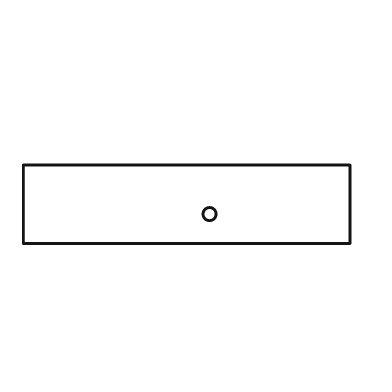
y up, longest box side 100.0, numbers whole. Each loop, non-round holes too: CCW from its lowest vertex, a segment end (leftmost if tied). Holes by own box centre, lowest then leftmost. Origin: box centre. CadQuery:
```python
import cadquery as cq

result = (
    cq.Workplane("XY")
    .moveTo(-50.0, -12.0)
    .lineTo(50.0, -12.0)
    .lineTo(50.0, 12.0)
    .lineTo(-50.0, 12.0)
    .close()
    .moveTo(7.0, -3.0)
    .circle(2.0)
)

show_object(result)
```